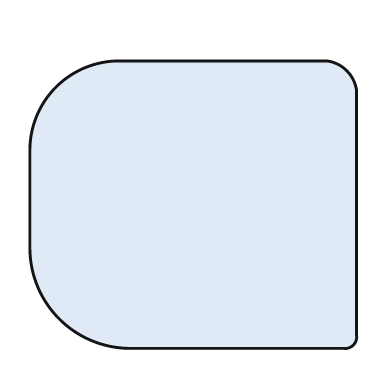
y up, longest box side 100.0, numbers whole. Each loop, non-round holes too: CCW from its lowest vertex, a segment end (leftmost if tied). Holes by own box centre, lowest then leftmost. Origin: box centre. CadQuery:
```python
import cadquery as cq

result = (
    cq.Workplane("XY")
    .moveTo(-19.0, -44.0)
    .lineTo(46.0, -44.0)
    .threePointArc((49.0, -43.0), (50.0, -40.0))
    .lineTo(50.0, 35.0)
    .threePointArc((47.0, 41.0), (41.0, 44.0))
    .lineTo(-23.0, 44.0)
    .threePointArc((-42.0, 36.0), (-50.0, 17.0))
    .lineTo(-50.0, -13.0)
    .threePointArc((-41.0, -35.0), (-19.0, -44.0))
    .close()
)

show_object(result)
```